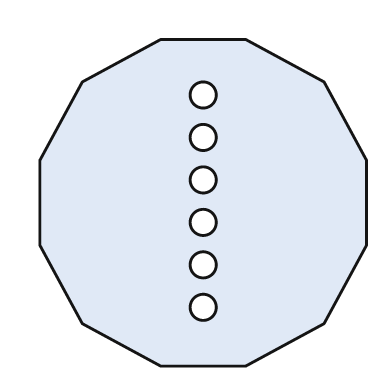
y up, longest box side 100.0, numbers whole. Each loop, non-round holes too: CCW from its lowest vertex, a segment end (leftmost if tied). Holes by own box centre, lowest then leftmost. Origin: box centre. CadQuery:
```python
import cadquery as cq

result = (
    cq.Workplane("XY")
    .moveTo(-13.0, -50.0)
    .lineTo(13.0, -50.0)
    .lineTo(37.0, -37.0)
    .lineTo(50.0, -13.0)
    .lineTo(50.0, 13.0)
    .lineTo(37.0, 37.0)
    .lineTo(13.0, 50.0)
    .lineTo(-13.0, 50.0)
    .lineTo(-37.0, 37.0)
    .lineTo(-50.0, 13.0)
    .lineTo(-50.0, -13.0)
    .lineTo(-37.0, -37.0)
    .close()
    .moveTo(0.0, -32.0)
    .circle(4.0)
    .moveTo(0.0, -19.0)
    .circle(4.0)
    .moveTo(0.0, -6.0)
    .circle(4.0)
    .moveTo(0.0, 7.0)
    .circle(4.0)
    .moveTo(0.0, 20.0)
    .circle(4.0)
    .moveTo(0.0, 33.0)
    .circle(4.0)
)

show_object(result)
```